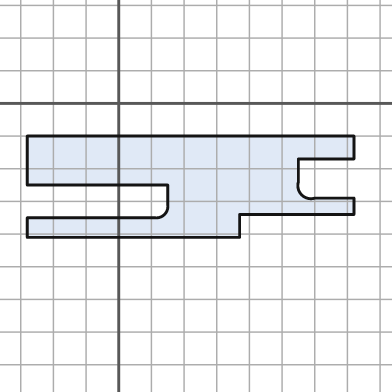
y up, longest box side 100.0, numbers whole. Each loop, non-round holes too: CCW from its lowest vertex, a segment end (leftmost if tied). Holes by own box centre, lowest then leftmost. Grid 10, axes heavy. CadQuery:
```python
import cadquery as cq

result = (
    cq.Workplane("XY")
    .moveTo(-28.0, -41.0)
    .lineTo(37.0, -41.0)
    .lineTo(37.0, -34.0)
    .lineTo(72.0, -34.0)
    .lineTo(72.0, -29.0)
    .lineTo(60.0, -29.0)
    .threePointArc((56.0, -28.0), (55.0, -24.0))
    .lineTo(55.0, -17.0)
    .lineTo(72.0, -17.0)
    .lineTo(72.0, -10.0)
    .lineTo(-28.0, -10.0)
    .lineTo(-28.0, -25.0)
    .lineTo(15.0, -25.0)
    .lineTo(15.0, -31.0)
    .threePointArc((14.0, -34.0), (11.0, -35.0))
    .lineTo(-28.0, -35.0)
    .close()
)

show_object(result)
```